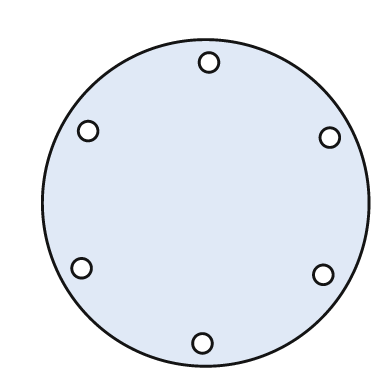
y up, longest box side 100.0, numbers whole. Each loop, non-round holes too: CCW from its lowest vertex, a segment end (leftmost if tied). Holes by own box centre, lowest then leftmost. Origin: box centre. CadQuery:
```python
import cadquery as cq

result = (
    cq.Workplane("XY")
    .moveTo(0.0, 0.0)
    .circle(50.0)
    .moveTo(-1.0, -43.0)
    .circle(3.0)
    .moveTo(36.0, -22.0)
    .circle(3.0)
    .moveTo(-38.0, -20.0)
    .circle(3.0)
    .moveTo(38.0, 20.0)
    .circle(3.0)
    .moveTo(-36.0, 22.0)
    .circle(3.0)
    .moveTo(1.0, 43.0)
    .circle(3.0)
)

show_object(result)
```